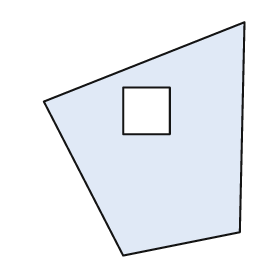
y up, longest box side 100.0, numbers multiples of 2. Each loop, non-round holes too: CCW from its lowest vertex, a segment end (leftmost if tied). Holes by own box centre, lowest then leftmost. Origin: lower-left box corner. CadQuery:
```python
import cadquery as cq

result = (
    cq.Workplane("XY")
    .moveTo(34.0, 0.0)
    .lineTo(84.0, 10.0)
    .lineTo(86.0, 100.0)
    .lineTo(0.0, 66.0)
    .close()
    .moveTo(34.0, 52.0)
    .lineTo(54.0, 52.0)
    .lineTo(54.0, 72.0)
    .lineTo(34.0, 72.0)
    .close()
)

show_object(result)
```